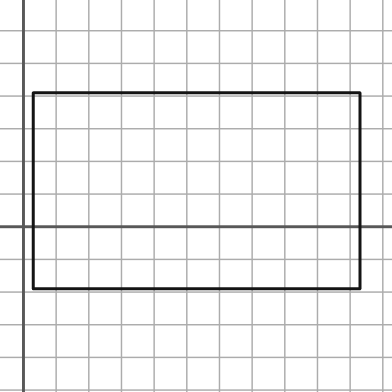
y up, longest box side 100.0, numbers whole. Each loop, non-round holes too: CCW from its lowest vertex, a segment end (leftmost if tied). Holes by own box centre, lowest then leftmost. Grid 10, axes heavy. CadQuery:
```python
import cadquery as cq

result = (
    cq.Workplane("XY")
    .moveTo(3.0, -19.0)
    .lineTo(103.0, -19.0)
    .lineTo(103.0, 41.0)
    .lineTo(3.0, 41.0)
    .close()
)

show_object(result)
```